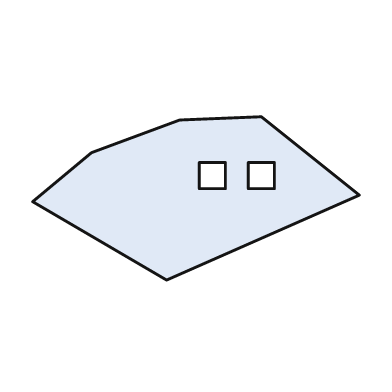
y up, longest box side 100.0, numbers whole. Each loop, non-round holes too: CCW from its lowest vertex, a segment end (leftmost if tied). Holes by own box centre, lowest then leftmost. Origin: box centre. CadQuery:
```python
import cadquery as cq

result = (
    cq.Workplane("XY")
    .moveTo(-9.0, -25.0)
    .lineTo(50.0, 1.0)
    .lineTo(20.0, 25.0)
    .lineTo(-5.0, 24.0)
    .lineTo(-32.0, 14.0)
    .lineTo(-50.0, -1.0)
    .close()
    .moveTo(1.0, 3.0)
    .lineTo(9.0, 3.0)
    .lineTo(9.0, 11.0)
    .lineTo(1.0, 11.0)
    .close()
    .moveTo(16.0, 3.0)
    .lineTo(24.0, 3.0)
    .lineTo(24.0, 11.0)
    .lineTo(16.0, 11.0)
    .close()
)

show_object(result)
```